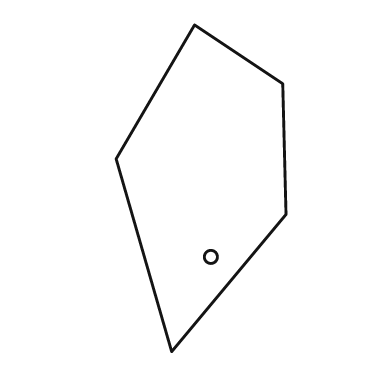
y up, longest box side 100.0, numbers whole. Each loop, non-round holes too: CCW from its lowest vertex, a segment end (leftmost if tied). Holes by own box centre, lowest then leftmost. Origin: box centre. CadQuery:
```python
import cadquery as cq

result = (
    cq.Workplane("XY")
    .moveTo(-9.0, -50.0)
    .lineTo(26.0, -8.0)
    .lineTo(25.0, 32.0)
    .lineTo(-2.0, 50.0)
    .lineTo(-26.0, 9.0)
    .close()
    .moveTo(3.0, -21.0)
    .circle(2.0)
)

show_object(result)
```